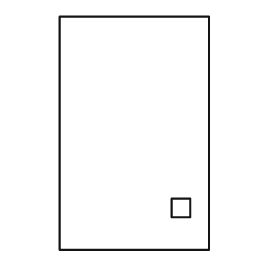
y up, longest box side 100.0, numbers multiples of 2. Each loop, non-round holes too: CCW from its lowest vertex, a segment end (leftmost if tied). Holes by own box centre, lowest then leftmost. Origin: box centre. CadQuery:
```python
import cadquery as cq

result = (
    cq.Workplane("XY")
    .moveTo(-32.0, -50.0)
    .lineTo(32.0, -50.0)
    .lineTo(32.0, 50.0)
    .lineTo(-32.0, 50.0)
    .close()
    .moveTo(16.0, -36.0)
    .lineTo(24.0, -36.0)
    .lineTo(24.0, -28.0)
    .lineTo(16.0, -28.0)
    .close()
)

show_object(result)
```